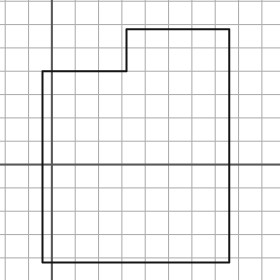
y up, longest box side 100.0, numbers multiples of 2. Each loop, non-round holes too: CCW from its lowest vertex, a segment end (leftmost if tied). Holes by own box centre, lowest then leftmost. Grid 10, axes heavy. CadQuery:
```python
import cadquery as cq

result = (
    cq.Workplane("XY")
    .moveTo(-4.0, -42.0)
    .lineTo(76.0, -42.0)
    .lineTo(76.0, 58.0)
    .lineTo(32.0, 58.0)
    .lineTo(32.0, 40.0)
    .lineTo(-4.0, 40.0)
    .close()
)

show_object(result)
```